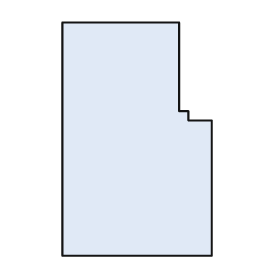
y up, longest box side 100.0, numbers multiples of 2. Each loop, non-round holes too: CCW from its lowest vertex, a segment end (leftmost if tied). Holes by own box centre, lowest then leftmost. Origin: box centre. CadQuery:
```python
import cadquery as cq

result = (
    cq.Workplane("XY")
    .moveTo(-32.0, -50.0)
    .lineTo(32.0, -50.0)
    .lineTo(32.0, 8.0)
    .lineTo(22.0, 8.0)
    .lineTo(22.0, 12.0)
    .lineTo(18.0, 12.0)
    .lineTo(18.0, 50.0)
    .lineTo(-32.0, 50.0)
    .close()
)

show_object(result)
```